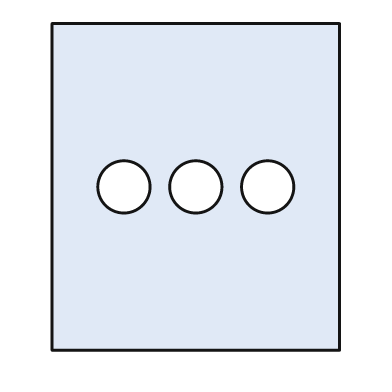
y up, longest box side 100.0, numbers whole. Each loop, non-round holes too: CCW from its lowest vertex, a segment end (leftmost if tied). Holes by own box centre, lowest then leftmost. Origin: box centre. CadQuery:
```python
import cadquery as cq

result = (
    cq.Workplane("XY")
    .moveTo(-44.0, -50.0)
    .lineTo(44.0, -50.0)
    .lineTo(44.0, 50.0)
    .lineTo(-44.0, 50.0)
    .close()
    .moveTo(-22.0, 0.0)
    .circle(8.0)
    .moveTo(0.0, 0.0)
    .circle(8.0)
    .moveTo(22.0, 0.0)
    .circle(8.0)
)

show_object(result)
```